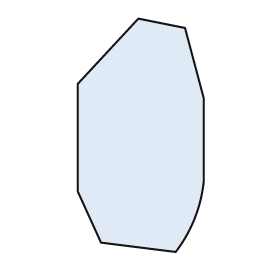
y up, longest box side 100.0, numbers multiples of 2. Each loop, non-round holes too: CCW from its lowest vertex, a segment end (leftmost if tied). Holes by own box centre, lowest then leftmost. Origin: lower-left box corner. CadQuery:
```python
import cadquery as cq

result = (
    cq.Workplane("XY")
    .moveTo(42.0, 0.0)
    .threePointArc((50.0, 14.0), (54.0, 30.0))
    .lineTo(54.0, 66.0)
    .lineTo(46.0, 96.0)
    .lineTo(26.0, 100.0)
    .lineTo(0.0, 72.0)
    .lineTo(0.0, 26.0)
    .lineTo(10.0, 4.0)
    .close()
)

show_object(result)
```